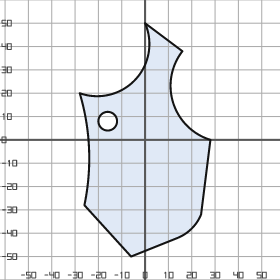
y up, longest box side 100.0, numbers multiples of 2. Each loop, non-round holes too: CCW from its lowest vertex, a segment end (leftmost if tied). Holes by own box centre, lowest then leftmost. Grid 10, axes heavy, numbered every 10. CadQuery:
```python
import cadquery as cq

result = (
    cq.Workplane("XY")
    .moveTo(-6.0, -50.0)
    .lineTo(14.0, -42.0)
    .threePointArc((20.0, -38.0), (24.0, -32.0))
    .lineTo(28.0, 0.0)
    .threePointArc((12.0, 16.0), (16.0, 38.0))
    .lineTo(0.0, 50.0)
    .threePointArc((-4.0, 26.0), (-28.0, 20.0))
    .threePointArc((-24.0, -4.0), (-26.0, -28.0))
    .close()
    .moveTo(-16.0, 8.0)
    .circle(4.0)
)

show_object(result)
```